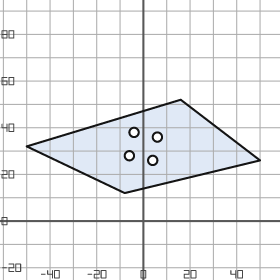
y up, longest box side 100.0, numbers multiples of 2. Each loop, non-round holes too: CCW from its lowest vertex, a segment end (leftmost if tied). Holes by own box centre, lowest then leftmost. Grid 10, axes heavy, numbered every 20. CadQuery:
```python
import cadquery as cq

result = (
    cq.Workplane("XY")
    .moveTo(-8.0, 12.0)
    .lineTo(50.0, 26.0)
    .lineTo(16.0, 52.0)
    .lineTo(-50.0, 32.0)
    .close()
    .moveTo(4.0, 26.0)
    .circle(2.0)
    .moveTo(-6.0, 28.0)
    .circle(2.0)
    .moveTo(6.0, 36.0)
    .circle(2.0)
    .moveTo(-4.0, 38.0)
    .circle(2.0)
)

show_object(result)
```